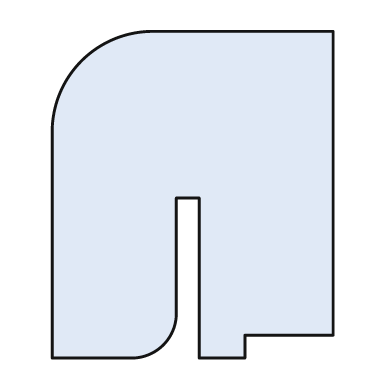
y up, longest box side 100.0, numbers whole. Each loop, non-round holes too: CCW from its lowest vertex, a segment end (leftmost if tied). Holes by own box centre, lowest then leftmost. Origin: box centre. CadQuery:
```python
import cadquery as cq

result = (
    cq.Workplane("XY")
    .moveTo(-43.0, -50.0)
    .lineTo(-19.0, -50.0)
    .threePointArc((-9.0, -46.0), (-5.0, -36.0))
    .lineTo(-5.0, -1.0)
    .lineTo(2.0, -1.0)
    .lineTo(2.0, -50.0)
    .lineTo(16.0, -50.0)
    .lineTo(16.0, -43.0)
    .lineTo(43.0, -43.0)
    .lineTo(43.0, 50.0)
    .lineTo(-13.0, 50.0)
    .threePointArc((-34.0, 41.0), (-43.0, 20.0))
    .close()
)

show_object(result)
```